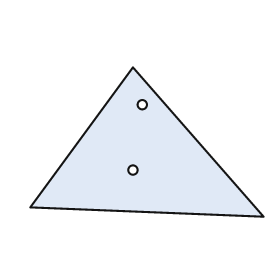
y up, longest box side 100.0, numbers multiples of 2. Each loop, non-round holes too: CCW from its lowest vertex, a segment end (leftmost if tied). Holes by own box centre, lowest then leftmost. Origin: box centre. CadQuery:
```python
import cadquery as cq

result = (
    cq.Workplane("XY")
    .moveTo(50.0, -32.0)
    .lineTo(-6.0, 32.0)
    .lineTo(-50.0, -28.0)
    .close()
    .moveTo(-6.0, -12.0)
    .circle(2.0)
    .moveTo(-2.0, 16.0)
    .circle(2.0)
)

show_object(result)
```